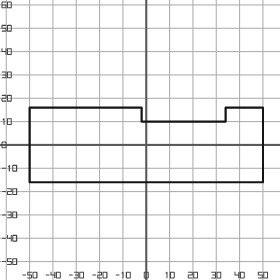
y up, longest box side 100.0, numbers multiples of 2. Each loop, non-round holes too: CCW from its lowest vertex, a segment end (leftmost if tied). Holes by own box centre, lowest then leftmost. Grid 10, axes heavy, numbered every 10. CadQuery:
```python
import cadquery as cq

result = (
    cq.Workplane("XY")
    .moveTo(-50.0, -16.0)
    .lineTo(50.0, -16.0)
    .lineTo(50.0, 16.0)
    .lineTo(34.0, 16.0)
    .lineTo(34.0, 10.0)
    .lineTo(-2.0, 10.0)
    .lineTo(-2.0, 16.0)
    .lineTo(-50.0, 16.0)
    .close()
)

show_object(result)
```